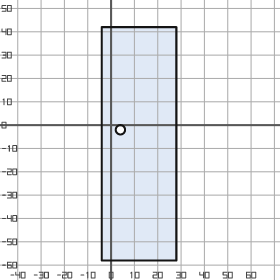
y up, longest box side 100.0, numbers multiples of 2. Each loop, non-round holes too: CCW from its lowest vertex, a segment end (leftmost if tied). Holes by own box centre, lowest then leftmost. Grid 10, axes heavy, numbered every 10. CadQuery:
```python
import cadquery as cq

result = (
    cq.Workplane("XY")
    .moveTo(-4.0, -58.0)
    .lineTo(28.0, -58.0)
    .lineTo(28.0, 42.0)
    .lineTo(-4.0, 42.0)
    .close()
    .moveTo(4.0, -2.0)
    .circle(2.0)
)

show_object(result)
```